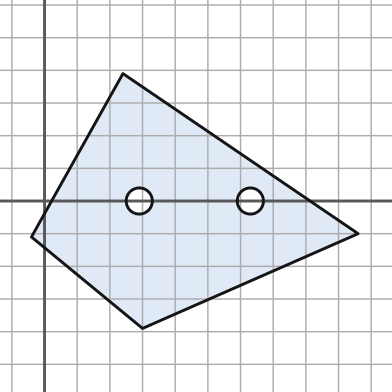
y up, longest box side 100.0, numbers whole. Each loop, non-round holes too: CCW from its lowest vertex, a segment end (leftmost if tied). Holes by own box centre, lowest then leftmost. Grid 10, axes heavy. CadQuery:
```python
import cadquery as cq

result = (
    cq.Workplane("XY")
    .moveTo(30.0, -39.0)
    .lineTo(96.0, -10.0)
    .lineTo(24.0, 39.0)
    .lineTo(-4.0, -11.0)
    .close()
    .moveTo(29.0, 0.0)
    .circle(4.0)
    .moveTo(63.0, 0.0)
    .circle(4.0)
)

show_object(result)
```